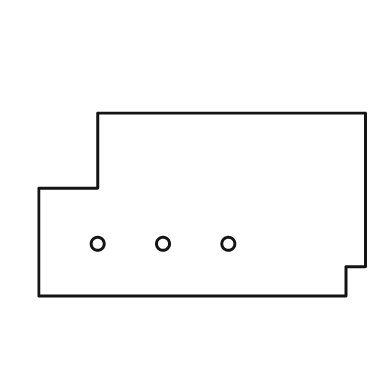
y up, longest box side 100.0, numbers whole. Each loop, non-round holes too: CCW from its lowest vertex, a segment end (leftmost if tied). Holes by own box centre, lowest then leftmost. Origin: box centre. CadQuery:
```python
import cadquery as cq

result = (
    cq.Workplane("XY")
    .moveTo(-50.0, -28.0)
    .lineTo(44.0, -28.0)
    .lineTo(44.0, -19.0)
    .lineTo(50.0, -19.0)
    .lineTo(50.0, 28.0)
    .lineTo(-32.0, 28.0)
    .lineTo(-32.0, 5.0)
    .lineTo(-50.0, 5.0)
    .close()
    .moveTo(-32.0, -12.0)
    .circle(2.0)
    .moveTo(-12.0, -12.0)
    .circle(2.0)
    .moveTo(8.0, -12.0)
    .circle(2.0)
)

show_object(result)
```